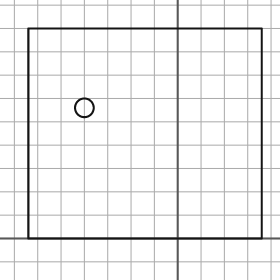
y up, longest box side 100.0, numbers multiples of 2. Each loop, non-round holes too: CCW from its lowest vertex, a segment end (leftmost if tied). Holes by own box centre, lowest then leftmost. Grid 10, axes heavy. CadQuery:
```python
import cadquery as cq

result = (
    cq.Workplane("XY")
    .moveTo(-64.0, 0.0)
    .lineTo(36.0, 0.0)
    .lineTo(36.0, 90.0)
    .lineTo(-64.0, 90.0)
    .close()
    .moveTo(-40.0, 56.0)
    .circle(4.0)
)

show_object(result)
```